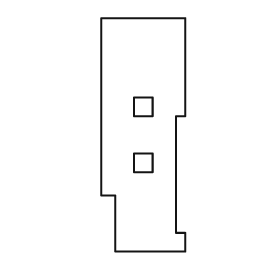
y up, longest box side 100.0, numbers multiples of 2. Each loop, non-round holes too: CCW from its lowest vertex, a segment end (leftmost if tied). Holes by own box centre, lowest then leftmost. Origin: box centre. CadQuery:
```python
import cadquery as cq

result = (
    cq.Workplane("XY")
    .moveTo(-12.0, -50.0)
    .lineTo(18.0, -50.0)
    .lineTo(18.0, -42.0)
    .lineTo(14.0, -42.0)
    .lineTo(14.0, 8.0)
    .lineTo(18.0, 8.0)
    .lineTo(18.0, 50.0)
    .lineTo(-18.0, 50.0)
    .lineTo(-18.0, -26.0)
    .lineTo(-12.0, -26.0)
    .close()
    .moveTo(-4.0, -16.0)
    .lineTo(4.0, -16.0)
    .lineTo(4.0, -8.0)
    .lineTo(-4.0, -8.0)
    .close()
    .moveTo(-4.0, 8.0)
    .lineTo(4.0, 8.0)
    .lineTo(4.0, 16.0)
    .lineTo(-4.0, 16.0)
    .close()
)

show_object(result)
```